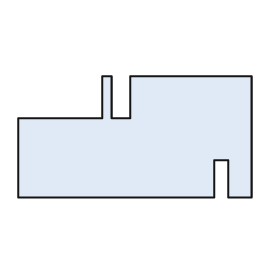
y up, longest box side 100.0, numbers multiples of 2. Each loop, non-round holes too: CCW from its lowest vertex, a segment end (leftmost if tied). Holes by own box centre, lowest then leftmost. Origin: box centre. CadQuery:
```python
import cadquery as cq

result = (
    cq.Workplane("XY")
    .moveTo(-50.0, -26.0)
    .lineTo(34.0, -26.0)
    .lineTo(34.0, -10.0)
    .lineTo(40.0, -10.0)
    .lineTo(40.0, -26.0)
    .lineTo(50.0, -26.0)
    .lineTo(50.0, 26.0)
    .lineTo(-2.0, 26.0)
    .lineTo(-2.0, 8.0)
    .lineTo(-10.0, 8.0)
    .lineTo(-10.0, 26.0)
    .lineTo(-14.0, 26.0)
    .lineTo(-14.0, 8.0)
    .lineTo(-50.0, 8.0)
    .close()
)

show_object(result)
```